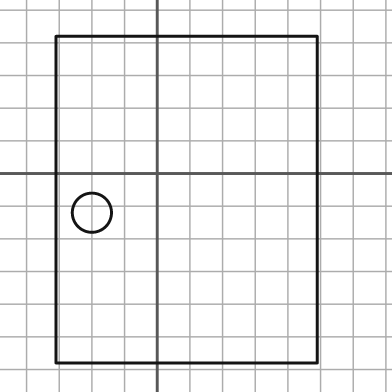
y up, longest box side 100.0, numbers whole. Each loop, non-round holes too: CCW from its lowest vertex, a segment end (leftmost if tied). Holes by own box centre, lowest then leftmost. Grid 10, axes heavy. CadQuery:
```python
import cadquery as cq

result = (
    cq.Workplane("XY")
    .moveTo(-31.0, -58.0)
    .lineTo(49.0, -58.0)
    .lineTo(49.0, 42.0)
    .lineTo(-31.0, 42.0)
    .close()
    .moveTo(-20.0, -12.0)
    .circle(6.0)
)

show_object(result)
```